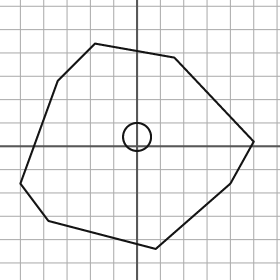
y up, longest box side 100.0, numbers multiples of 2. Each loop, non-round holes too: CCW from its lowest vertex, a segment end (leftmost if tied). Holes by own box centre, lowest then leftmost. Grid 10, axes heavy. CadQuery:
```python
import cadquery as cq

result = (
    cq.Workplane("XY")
    .moveTo(8.0, -44.0)
    .lineTo(40.0, -16.0)
    .lineTo(50.0, 2.0)
    .lineTo(16.0, 38.0)
    .lineTo(-18.0, 44.0)
    .lineTo(-34.0, 28.0)
    .lineTo(-50.0, -16.0)
    .lineTo(-38.0, -32.0)
    .close()
    .moveTo(0.0, 4.0)
    .circle(6.0)
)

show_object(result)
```